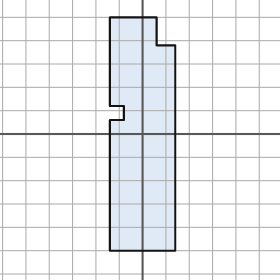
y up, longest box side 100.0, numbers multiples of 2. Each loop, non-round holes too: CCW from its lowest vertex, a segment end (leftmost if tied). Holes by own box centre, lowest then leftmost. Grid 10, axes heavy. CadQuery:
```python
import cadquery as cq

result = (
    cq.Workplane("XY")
    .moveTo(-14.0, -50.0)
    .lineTo(14.0, -50.0)
    .lineTo(14.0, 38.0)
    .lineTo(6.0, 38.0)
    .lineTo(6.0, 50.0)
    .lineTo(-14.0, 50.0)
    .lineTo(-14.0, 12.0)
    .lineTo(-8.0, 12.0)
    .lineTo(-8.0, 6.0)
    .lineTo(-14.0, 6.0)
    .close()
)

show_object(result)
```